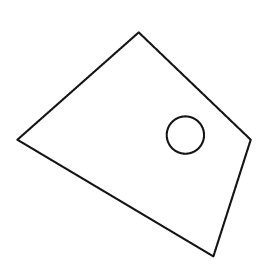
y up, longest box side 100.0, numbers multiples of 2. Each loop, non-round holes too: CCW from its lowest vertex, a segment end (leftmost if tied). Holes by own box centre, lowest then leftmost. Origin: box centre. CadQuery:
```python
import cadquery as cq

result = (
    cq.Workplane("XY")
    .moveTo(34.0, -48.0)
    .lineTo(50.0, 2.0)
    .lineTo(2.0, 48.0)
    .lineTo(-50.0, 2.0)
    .close()
    .moveTo(22.0, 4.0)
    .circle(8.0)
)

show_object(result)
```